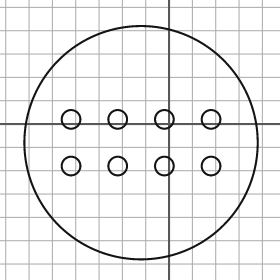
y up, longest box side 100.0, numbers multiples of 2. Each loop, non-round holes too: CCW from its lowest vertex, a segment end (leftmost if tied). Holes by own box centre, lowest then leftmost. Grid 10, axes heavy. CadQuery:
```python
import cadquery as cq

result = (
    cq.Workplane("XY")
    .moveTo(-12.0, -8.0)
    .circle(50.0)
    .moveTo(-42.0, -18.0)
    .circle(4.0)
    .moveTo(-22.0, -18.0)
    .circle(4.0)
    .moveTo(-2.0, -18.0)
    .circle(4.0)
    .moveTo(18.0, -18.0)
    .circle(4.0)
    .moveTo(-42.0, 2.0)
    .circle(4.0)
    .moveTo(-22.0, 2.0)
    .circle(4.0)
    .moveTo(-2.0, 2.0)
    .circle(4.0)
    .moveTo(18.0, 2.0)
    .circle(4.0)
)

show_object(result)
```